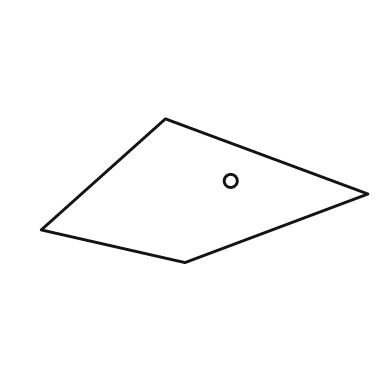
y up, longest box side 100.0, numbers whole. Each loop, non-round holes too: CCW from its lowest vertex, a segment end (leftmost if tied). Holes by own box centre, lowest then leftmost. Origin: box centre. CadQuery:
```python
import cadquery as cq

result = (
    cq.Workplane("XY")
    .moveTo(-6.0, -22.0)
    .lineTo(50.0, -1.0)
    .lineTo(-12.0, 22.0)
    .lineTo(-50.0, -12.0)
    .close()
    .moveTo(8.0, 3.0)
    .circle(2.0)
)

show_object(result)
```